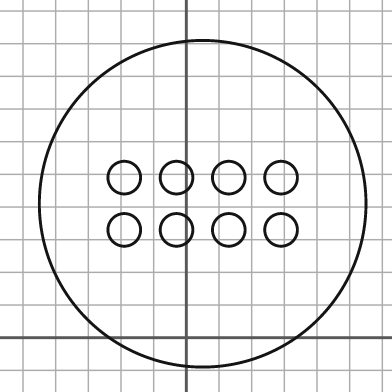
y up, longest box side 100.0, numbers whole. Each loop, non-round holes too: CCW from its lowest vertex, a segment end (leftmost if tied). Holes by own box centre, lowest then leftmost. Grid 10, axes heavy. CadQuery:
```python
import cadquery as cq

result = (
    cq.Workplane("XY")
    .moveTo(5.0, 41.0)
    .circle(50.0)
    .moveTo(-19.0, 33.0)
    .circle(5.0)
    .moveTo(-3.0, 33.0)
    .circle(5.0)
    .moveTo(13.0, 33.0)
    .circle(5.0)
    .moveTo(29.0, 33.0)
    .circle(5.0)
    .moveTo(-19.0, 49.0)
    .circle(5.0)
    .moveTo(-3.0, 49.0)
    .circle(5.0)
    .moveTo(13.0, 49.0)
    .circle(5.0)
    .moveTo(29.0, 49.0)
    .circle(5.0)
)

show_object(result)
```